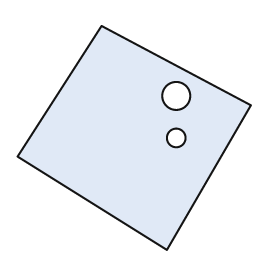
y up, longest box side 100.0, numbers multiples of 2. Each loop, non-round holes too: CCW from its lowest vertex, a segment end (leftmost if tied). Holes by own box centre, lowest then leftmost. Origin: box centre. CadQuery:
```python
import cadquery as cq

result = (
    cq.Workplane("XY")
    .moveTo(14.0, -48.0)
    .lineTo(50.0, 14.0)
    .lineTo(-14.0, 48.0)
    .lineTo(-50.0, -8.0)
    .close()
    .moveTo(18.0, 0.0)
    .circle(4.0)
    .moveTo(18.0, 18.0)
    .circle(6.0)
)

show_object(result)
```